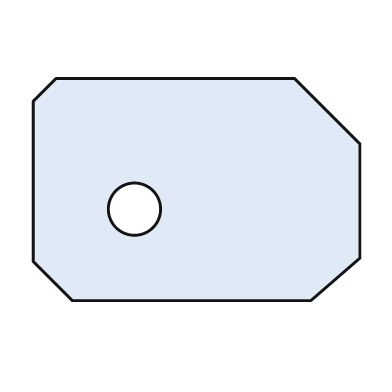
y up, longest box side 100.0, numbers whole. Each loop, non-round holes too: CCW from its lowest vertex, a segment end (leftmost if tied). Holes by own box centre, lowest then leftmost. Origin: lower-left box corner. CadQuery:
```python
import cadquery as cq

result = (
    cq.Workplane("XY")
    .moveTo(12.0, 0.0)
    .lineTo(85.0, 0.0)
    .lineTo(100.0, 13.0)
    .lineTo(100.0, 48.0)
    .lineTo(80.0, 68.0)
    .lineTo(7.0, 68.0)
    .lineTo(0.0, 61.0)
    .lineTo(0.0, 12.0)
    .close()
    .moveTo(31.0, 28.0)
    .circle(8.0)
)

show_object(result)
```